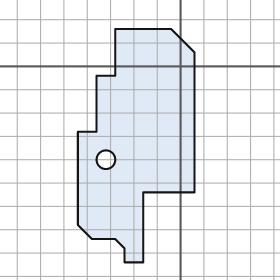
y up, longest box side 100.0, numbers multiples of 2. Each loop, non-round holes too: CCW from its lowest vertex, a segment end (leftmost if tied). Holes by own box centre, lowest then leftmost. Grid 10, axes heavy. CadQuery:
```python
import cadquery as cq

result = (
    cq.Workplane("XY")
    .moveTo(-24.0, -84.0)
    .lineTo(-16.0, -84.0)
    .lineTo(-16.0, -54.0)
    .lineTo(6.0, -54.0)
    .lineTo(6.0, 6.0)
    .lineTo(-4.0, 16.0)
    .lineTo(-28.0, 16.0)
    .lineTo(-28.0, -4.0)
    .lineTo(-36.0, -4.0)
    .lineTo(-36.0, -28.0)
    .lineTo(-44.0, -28.0)
    .lineTo(-44.0, -68.0)
    .lineTo(-38.0, -74.0)
    .lineTo(-28.0, -74.0)
    .lineTo(-24.0, -78.0)
    .close()
    .moveTo(-32.0, -40.0)
    .circle(4.0)
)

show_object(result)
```